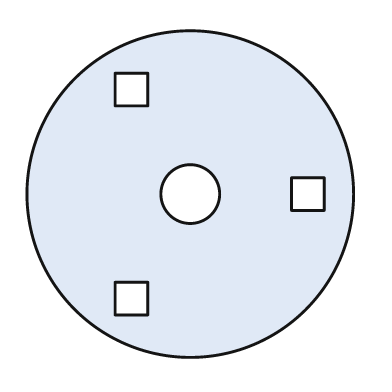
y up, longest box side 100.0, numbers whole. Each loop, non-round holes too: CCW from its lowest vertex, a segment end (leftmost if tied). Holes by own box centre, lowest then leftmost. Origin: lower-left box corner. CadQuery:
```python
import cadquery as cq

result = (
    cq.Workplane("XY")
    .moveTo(50.0, 50.0)
    .circle(50.0)
    .moveTo(27.0, 13.0)
    .lineTo(37.0, 13.0)
    .lineTo(37.0, 23.0)
    .lineTo(27.0, 23.0)
    .close()
    .moveTo(50.0, 50.0)
    .circle(9.0)
    .moveTo(81.0, 45.0)
    .lineTo(91.0, 45.0)
    .lineTo(91.0, 55.0)
    .lineTo(81.0, 55.0)
    .close()
    .moveTo(27.0, 77.0)
    .lineTo(37.0, 77.0)
    .lineTo(37.0, 87.0)
    .lineTo(27.0, 87.0)
    .close()
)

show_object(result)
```